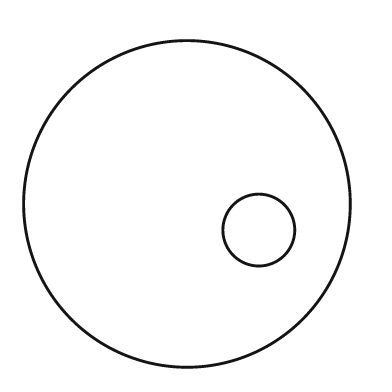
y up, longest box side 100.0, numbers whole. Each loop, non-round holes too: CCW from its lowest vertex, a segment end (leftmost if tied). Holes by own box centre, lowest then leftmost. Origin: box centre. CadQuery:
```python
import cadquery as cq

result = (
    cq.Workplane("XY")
    .moveTo(0.0, 0.0)
    .circle(50.0)
    .moveTo(22.0, -8.0)
    .circle(11.0)
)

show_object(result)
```